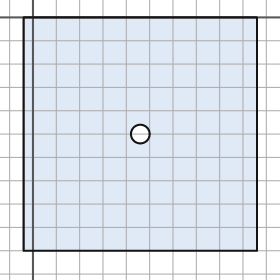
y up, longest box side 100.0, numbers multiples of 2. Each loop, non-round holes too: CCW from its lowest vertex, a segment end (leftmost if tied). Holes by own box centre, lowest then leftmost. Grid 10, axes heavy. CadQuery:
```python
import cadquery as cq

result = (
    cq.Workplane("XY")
    .moveTo(-4.0, -100.0)
    .lineTo(96.0, -100.0)
    .lineTo(96.0, 0.0)
    .lineTo(-4.0, 0.0)
    .close()
    .moveTo(46.0, -50.0)
    .circle(4.0)
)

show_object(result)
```